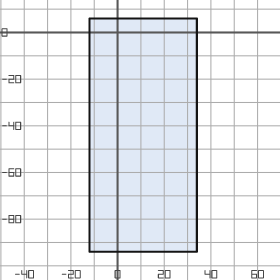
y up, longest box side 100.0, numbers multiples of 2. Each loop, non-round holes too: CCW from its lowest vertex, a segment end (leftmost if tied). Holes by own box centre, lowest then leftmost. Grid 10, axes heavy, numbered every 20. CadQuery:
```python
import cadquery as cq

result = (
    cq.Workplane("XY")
    .moveTo(-12.0, -94.0)
    .lineTo(34.0, -94.0)
    .lineTo(34.0, 6.0)
    .lineTo(-12.0, 6.0)
    .close()
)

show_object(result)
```